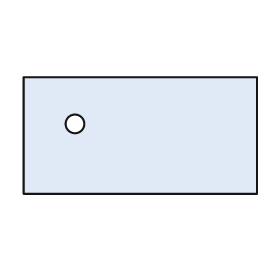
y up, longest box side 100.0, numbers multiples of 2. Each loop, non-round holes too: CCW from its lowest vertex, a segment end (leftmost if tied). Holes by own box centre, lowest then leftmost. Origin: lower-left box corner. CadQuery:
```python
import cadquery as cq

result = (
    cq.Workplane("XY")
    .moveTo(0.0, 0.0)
    .lineTo(100.0, 0.0)
    .lineTo(100.0, 50.0)
    .lineTo(0.0, 50.0)
    .close()
    .moveTo(22.0, 30.0)
    .circle(4.0)
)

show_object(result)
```